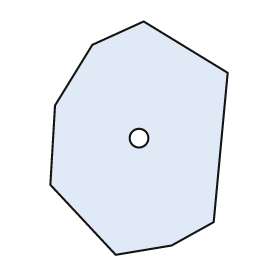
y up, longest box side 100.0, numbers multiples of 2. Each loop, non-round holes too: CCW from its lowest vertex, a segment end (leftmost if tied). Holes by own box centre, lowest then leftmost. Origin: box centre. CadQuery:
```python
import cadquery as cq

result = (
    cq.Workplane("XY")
    .moveTo(-10.0, -50.0)
    .lineTo(14.0, -46.0)
    .lineTo(32.0, -36.0)
    .lineTo(38.0, 28.0)
    .lineTo(2.0, 50.0)
    .lineTo(-20.0, 40.0)
    .lineTo(-36.0, 14.0)
    .lineTo(-38.0, -20.0)
    .close()
    .moveTo(0.0, 0.0)
    .circle(4.0)
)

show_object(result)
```